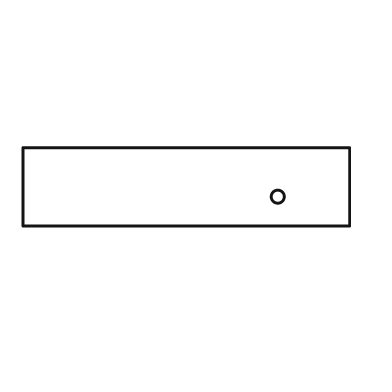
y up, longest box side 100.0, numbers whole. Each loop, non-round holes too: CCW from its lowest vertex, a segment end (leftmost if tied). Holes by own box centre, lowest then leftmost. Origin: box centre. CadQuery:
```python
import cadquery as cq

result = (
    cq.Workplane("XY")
    .moveTo(-50.0, -12.0)
    .lineTo(50.0, -12.0)
    .lineTo(50.0, 12.0)
    .lineTo(-50.0, 12.0)
    .close()
    .moveTo(28.0, -3.0)
    .circle(2.0)
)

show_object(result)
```